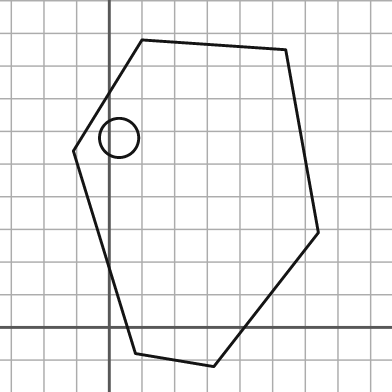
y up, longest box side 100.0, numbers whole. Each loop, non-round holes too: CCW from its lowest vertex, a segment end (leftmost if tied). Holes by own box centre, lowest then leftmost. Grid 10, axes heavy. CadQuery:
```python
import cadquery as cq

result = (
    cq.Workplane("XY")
    .moveTo(32.0, -12.0)
    .lineTo(64.0, 29.0)
    .lineTo(54.0, 85.0)
    .lineTo(10.0, 88.0)
    .lineTo(-11.0, 54.0)
    .lineTo(8.0, -8.0)
    .close()
    .moveTo(3.0, 58.0)
    .circle(6.0)
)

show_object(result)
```